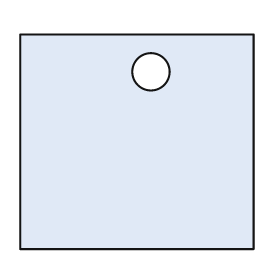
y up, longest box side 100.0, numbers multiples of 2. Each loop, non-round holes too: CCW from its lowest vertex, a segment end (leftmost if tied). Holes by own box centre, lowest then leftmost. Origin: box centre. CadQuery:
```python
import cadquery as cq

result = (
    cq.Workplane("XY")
    .moveTo(-50.0, -46.0)
    .lineTo(50.0, -46.0)
    .lineTo(50.0, 46.0)
    .lineTo(-50.0, 46.0)
    .close()
    .moveTo(6.0, 30.0)
    .circle(8.0)
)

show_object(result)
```